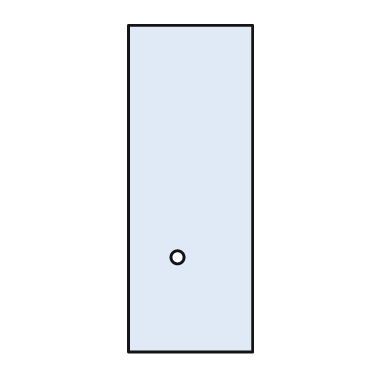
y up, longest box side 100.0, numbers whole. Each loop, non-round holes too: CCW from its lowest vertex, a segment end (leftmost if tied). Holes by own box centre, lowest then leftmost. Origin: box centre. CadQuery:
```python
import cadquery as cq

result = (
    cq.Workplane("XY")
    .moveTo(-19.0, -50.0)
    .lineTo(19.0, -50.0)
    .lineTo(19.0, 50.0)
    .lineTo(-19.0, 50.0)
    .close()
    .moveTo(-4.0, -21.0)
    .circle(2.0)
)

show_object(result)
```